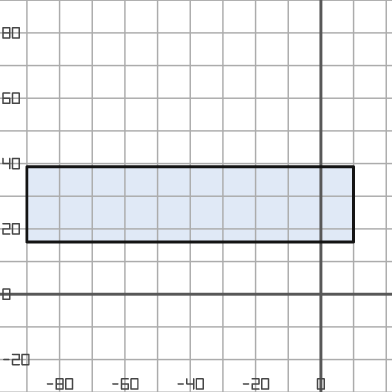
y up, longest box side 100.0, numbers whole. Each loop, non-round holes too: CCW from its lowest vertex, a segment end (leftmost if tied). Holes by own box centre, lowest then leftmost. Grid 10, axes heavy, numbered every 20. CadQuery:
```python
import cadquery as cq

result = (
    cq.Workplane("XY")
    .moveTo(-90.0, 16.0)
    .lineTo(10.0, 16.0)
    .lineTo(10.0, 39.0)
    .lineTo(-90.0, 39.0)
    .close()
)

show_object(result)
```